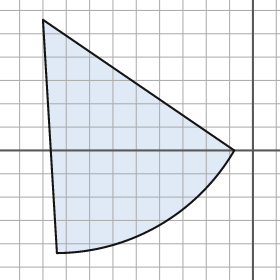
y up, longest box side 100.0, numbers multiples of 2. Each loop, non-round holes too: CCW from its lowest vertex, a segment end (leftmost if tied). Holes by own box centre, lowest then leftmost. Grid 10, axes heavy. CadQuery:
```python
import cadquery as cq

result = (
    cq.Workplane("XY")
    .moveTo(-84.0, -44.0)
    .threePointArc((-40.0, -32.0), (-8.0, 0.0))
    .lineTo(-90.0, 56.0)
    .close()
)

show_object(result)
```